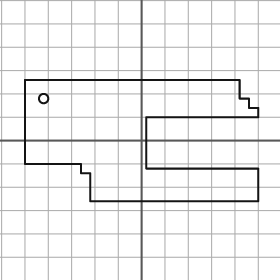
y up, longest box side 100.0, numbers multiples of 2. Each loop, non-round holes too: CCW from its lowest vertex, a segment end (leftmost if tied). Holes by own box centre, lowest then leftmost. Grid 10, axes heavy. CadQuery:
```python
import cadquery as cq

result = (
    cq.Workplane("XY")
    .moveTo(-22.0, -26.0)
    .lineTo(50.0, -26.0)
    .lineTo(50.0, -12.0)
    .lineTo(2.0, -12.0)
    .lineTo(2.0, 10.0)
    .lineTo(50.0, 10.0)
    .lineTo(50.0, 14.0)
    .lineTo(46.0, 14.0)
    .lineTo(46.0, 18.0)
    .lineTo(42.0, 18.0)
    .lineTo(42.0, 26.0)
    .lineTo(-50.0, 26.0)
    .lineTo(-50.0, -10.0)
    .lineTo(-26.0, -10.0)
    .lineTo(-26.0, -14.0)
    .lineTo(-22.0, -14.0)
    .close()
    .moveTo(-42.0, 18.0)
    .circle(2.0)
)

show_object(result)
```